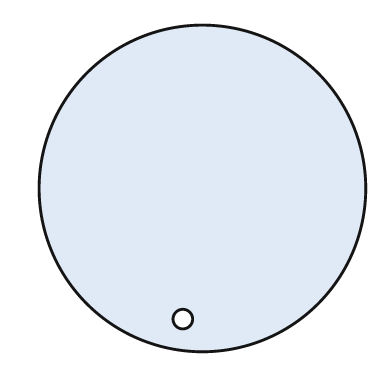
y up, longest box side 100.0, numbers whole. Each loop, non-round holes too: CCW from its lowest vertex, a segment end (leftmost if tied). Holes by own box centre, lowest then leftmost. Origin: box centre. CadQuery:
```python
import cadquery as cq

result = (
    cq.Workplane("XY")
    .moveTo(0.0, 0.0)
    .circle(50.0)
    .moveTo(-6.0, -40.0)
    .circle(3.0)
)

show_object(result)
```